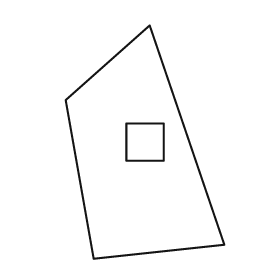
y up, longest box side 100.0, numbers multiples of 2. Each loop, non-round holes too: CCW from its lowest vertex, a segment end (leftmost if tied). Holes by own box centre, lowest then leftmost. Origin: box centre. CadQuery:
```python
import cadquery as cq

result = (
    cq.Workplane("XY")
    .moveTo(-22.0, -50.0)
    .lineTo(34.0, -44.0)
    .lineTo(2.0, 50.0)
    .lineTo(-34.0, 18.0)
    .close()
    .moveTo(-8.0, -8.0)
    .lineTo(8.0, -8.0)
    .lineTo(8.0, 8.0)
    .lineTo(-8.0, 8.0)
    .close()
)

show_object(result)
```